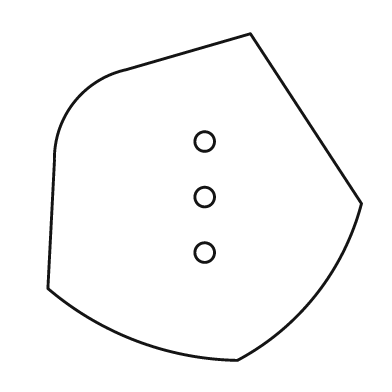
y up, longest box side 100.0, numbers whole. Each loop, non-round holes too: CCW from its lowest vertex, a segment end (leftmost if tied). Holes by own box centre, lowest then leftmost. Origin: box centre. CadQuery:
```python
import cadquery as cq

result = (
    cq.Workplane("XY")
    .moveTo(10.0, -50.0)
    .threePointArc((34.0, -30.0), (48.0, -2.0))
    .lineTo(14.0, 50.0)
    .lineTo(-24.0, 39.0)
    .threePointArc((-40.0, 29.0), (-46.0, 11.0))
    .lineTo(-48.0, -28.0)
    .threePointArc((-21.0, -44.0), (10.0, -50.0))
    .close()
    .moveTo(0.0, -17.0)
    .circle(3.0)
    .moveTo(0.0, 0.0)
    .circle(3.0)
    .moveTo(0.0, 17.0)
    .circle(3.0)
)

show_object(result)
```